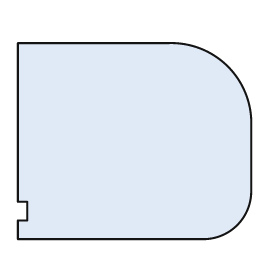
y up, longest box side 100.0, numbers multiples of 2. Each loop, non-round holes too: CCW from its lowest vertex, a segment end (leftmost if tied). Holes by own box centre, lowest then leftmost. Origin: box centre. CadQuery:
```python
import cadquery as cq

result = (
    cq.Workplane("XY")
    .moveTo(-50.0, -42.0)
    .lineTo(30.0, -42.0)
    .threePointArc((44.0, -36.0), (50.0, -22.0))
    .lineTo(50.0, 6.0)
    .threePointArc((40.0, 32.0), (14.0, 42.0))
    .lineTo(-50.0, 42.0)
    .lineTo(-50.0, -26.0)
    .lineTo(-46.0, -26.0)
    .lineTo(-46.0, -34.0)
    .lineTo(-50.0, -34.0)
    .close()
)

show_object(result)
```